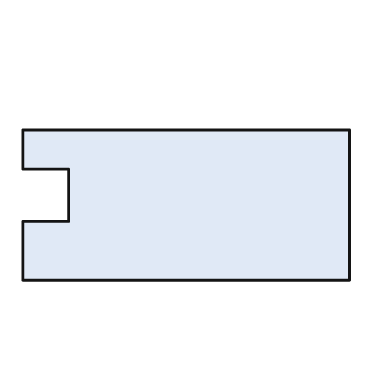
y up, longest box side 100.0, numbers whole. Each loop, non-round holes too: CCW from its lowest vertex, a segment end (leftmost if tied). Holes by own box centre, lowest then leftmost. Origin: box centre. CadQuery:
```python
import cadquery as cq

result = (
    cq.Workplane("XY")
    .moveTo(-50.0, -23.0)
    .lineTo(50.0, -23.0)
    .lineTo(50.0, 23.0)
    .lineTo(-50.0, 23.0)
    .lineTo(-50.0, 11.0)
    .lineTo(-36.0, 11.0)
    .lineTo(-36.0, -5.0)
    .lineTo(-50.0, -5.0)
    .close()
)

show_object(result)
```